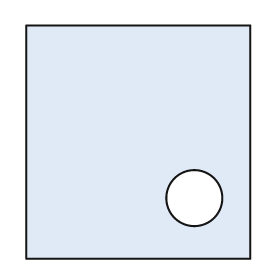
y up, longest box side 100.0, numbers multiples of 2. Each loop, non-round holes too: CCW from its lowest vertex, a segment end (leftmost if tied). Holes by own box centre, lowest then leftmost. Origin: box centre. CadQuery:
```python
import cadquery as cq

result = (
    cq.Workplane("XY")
    .moveTo(-48.0, -50.0)
    .lineTo(48.0, -50.0)
    .lineTo(48.0, 50.0)
    .lineTo(-48.0, 50.0)
    .close()
    .moveTo(24.0, -24.0)
    .circle(12.0)
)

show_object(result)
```